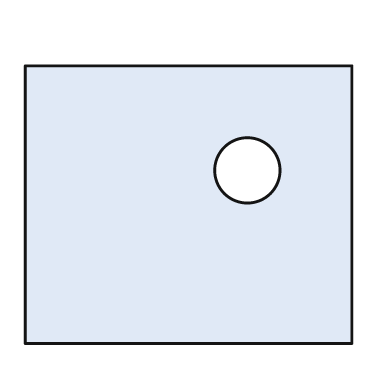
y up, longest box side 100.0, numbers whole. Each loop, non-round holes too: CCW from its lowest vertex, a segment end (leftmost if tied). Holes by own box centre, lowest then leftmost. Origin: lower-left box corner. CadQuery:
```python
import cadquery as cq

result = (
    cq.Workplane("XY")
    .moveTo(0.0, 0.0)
    .lineTo(100.0, 0.0)
    .lineTo(100.0, 85.0)
    .lineTo(0.0, 85.0)
    .close()
    .moveTo(68.0, 53.0)
    .circle(10.0)
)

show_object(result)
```